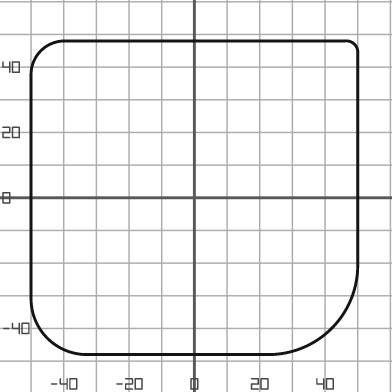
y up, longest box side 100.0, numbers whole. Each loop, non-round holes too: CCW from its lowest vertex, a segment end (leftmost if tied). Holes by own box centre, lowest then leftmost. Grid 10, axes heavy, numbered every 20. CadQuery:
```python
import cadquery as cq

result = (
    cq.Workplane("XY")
    .moveTo(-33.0, -48.0)
    .lineTo(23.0, -48.0)
    .threePointArc((42.0, -40.0), (50.0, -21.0))
    .lineTo(50.0, 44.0)
    .threePointArc((49.0, 47.0), (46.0, 48.0))
    .lineTo(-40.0, 48.0)
    .threePointArc((-47.0, 45.0), (-50.0, 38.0))
    .lineTo(-50.0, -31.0)
    .threePointArc((-45.0, -43.0), (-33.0, -48.0))
    .close()
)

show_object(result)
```